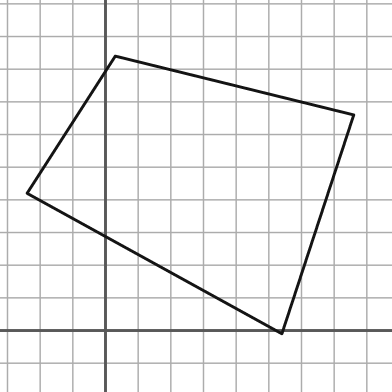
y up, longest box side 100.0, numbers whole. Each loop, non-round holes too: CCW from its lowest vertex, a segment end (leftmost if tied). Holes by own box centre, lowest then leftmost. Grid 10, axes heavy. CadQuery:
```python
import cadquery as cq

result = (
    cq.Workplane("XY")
    .moveTo(54.0, -1.0)
    .lineTo(76.0, 66.0)
    .lineTo(3.0, 84.0)
    .lineTo(-24.0, 42.0)
    .close()
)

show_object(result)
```